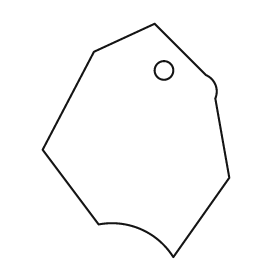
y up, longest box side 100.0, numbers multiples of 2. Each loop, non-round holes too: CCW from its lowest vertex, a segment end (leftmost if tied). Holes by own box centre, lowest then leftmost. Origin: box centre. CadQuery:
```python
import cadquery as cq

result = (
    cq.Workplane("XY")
    .moveTo(16.0, -50.0)
    .lineTo(40.0, -16.0)
    .lineTo(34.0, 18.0)
    .threePointArc((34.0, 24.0), (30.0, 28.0))
    .lineTo(8.0, 50.0)
    .lineTo(-18.0, 38.0)
    .lineTo(-40.0, -4.0)
    .lineTo(-16.0, -36.0)
    .threePointArc((2.0, -38.0), (16.0, -50.0))
    .close()
    .moveTo(12.0, 30.0)
    .circle(4.0)
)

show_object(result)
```